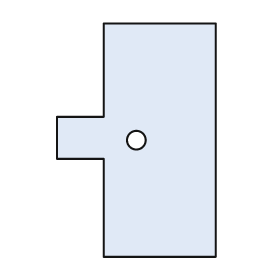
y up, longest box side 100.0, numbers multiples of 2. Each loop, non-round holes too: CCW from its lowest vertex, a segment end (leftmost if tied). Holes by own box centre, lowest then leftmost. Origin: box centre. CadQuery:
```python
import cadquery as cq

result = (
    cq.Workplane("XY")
    .moveTo(-14.0, -50.0)
    .lineTo(34.0, -50.0)
    .lineTo(34.0, 50.0)
    .lineTo(-14.0, 50.0)
    .lineTo(-14.0, 10.0)
    .lineTo(-34.0, 10.0)
    .lineTo(-34.0, -8.0)
    .lineTo(-14.0, -8.0)
    .close()
    .moveTo(0.0, 0.0)
    .circle(4.0)
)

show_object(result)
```